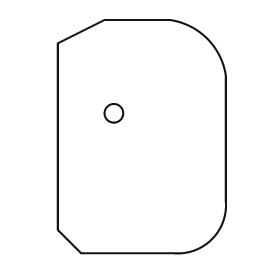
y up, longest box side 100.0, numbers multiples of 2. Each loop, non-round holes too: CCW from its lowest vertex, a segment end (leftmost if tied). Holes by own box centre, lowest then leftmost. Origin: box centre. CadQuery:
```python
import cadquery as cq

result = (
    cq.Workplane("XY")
    .moveTo(-26.0, -50.0)
    .lineTo(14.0, -50.0)
    .threePointArc((30.0, -44.0), (36.0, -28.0))
    .lineTo(36.0, 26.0)
    .threePointArc((28.0, 42.0), (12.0, 50.0))
    .lineTo(-16.0, 50.0)
    .lineTo(-36.0, 40.0)
    .lineTo(-36.0, -40.0)
    .close()
    .moveTo(-12.0, 10.0)
    .circle(4.0)
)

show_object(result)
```